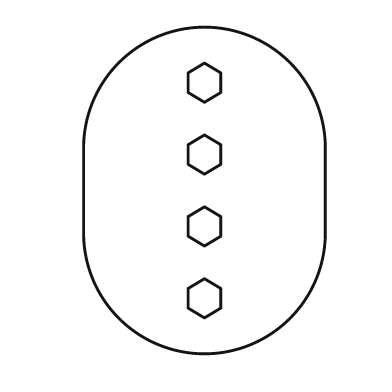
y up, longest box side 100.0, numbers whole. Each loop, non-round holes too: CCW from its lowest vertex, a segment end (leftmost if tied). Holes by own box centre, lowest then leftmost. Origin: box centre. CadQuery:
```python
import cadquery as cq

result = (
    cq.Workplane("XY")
    .moveTo(-37.0, -13.0)
    .threePointArc((0.0, -50.0), (37.0, -13.0))
    .lineTo(37.0, 13.0)
    .threePointArc((0.0, 50.0), (-37.0, 13.0))
    .close()
    .moveTo(0.0, -39.0)
    .lineTo(5.0, -36.0)
    .lineTo(5.0, -30.0)
    .lineTo(0.0, -27.0)
    .lineTo(-5.0, -30.0)
    .lineTo(-5.0, -36.0)
    .close()
    .moveTo(0.0, -17.0)
    .lineTo(5.0, -14.0)
    .lineTo(5.0, -8.0)
    .lineTo(0.0, -5.0)
    .lineTo(-5.0, -8.0)
    .lineTo(-5.0, -14.0)
    .close()
    .moveTo(0.0, 5.0)
    .lineTo(5.0, 8.0)
    .lineTo(5.0, 14.0)
    .lineTo(0.0, 17.0)
    .lineTo(-5.0, 14.0)
    .lineTo(-5.0, 8.0)
    .close()
    .moveTo(0.0, 27.0)
    .lineTo(5.0, 30.0)
    .lineTo(5.0, 36.0)
    .lineTo(0.0, 39.0)
    .lineTo(-5.0, 36.0)
    .lineTo(-5.0, 30.0)
    .close()
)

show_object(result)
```